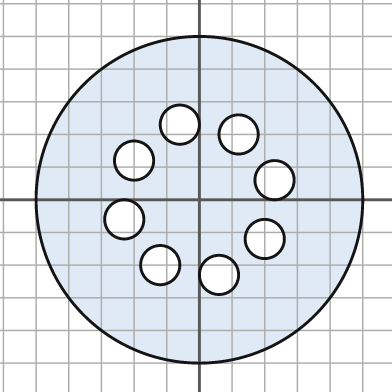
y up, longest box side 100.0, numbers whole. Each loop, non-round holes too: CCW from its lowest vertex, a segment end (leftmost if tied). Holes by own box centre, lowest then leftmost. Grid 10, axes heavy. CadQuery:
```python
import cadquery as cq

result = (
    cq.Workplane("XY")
    .moveTo(0.0, 0.0)
    .circle(50.0)
    .moveTo(6.0, -23.0)
    .circle(6.0)
    .moveTo(-12.0, -20.0)
    .circle(6.0)
    .moveTo(20.0, -12.0)
    .circle(6.0)
    .moveTo(-23.0, -6.0)
    .circle(6.0)
    .moveTo(23.0, 6.0)
    .circle(6.0)
    .moveTo(-20.0, 12.0)
    .circle(6.0)
    .moveTo(12.0, 20.0)
    .circle(6.0)
    .moveTo(-6.0, 23.0)
    .circle(6.0)
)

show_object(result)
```